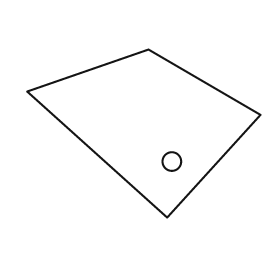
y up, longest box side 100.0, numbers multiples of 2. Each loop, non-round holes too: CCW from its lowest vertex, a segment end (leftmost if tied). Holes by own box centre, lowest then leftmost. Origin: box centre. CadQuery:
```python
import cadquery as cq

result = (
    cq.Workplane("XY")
    .moveTo(10.0, -36.0)
    .lineTo(50.0, 8.0)
    .lineTo(2.0, 36.0)
    .lineTo(-50.0, 18.0)
    .close()
    .moveTo(12.0, -12.0)
    .circle(4.0)
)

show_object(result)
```